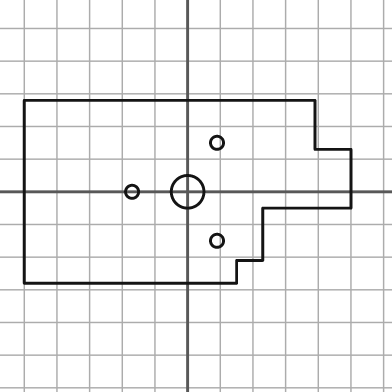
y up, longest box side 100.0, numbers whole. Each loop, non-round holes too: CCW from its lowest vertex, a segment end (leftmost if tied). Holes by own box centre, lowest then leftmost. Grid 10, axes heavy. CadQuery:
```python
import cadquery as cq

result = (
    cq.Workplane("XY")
    .moveTo(-50.0, -28.0)
    .lineTo(15.0, -28.0)
    .lineTo(15.0, -21.0)
    .lineTo(23.0, -21.0)
    .lineTo(23.0, -5.0)
    .lineTo(50.0, -5.0)
    .lineTo(50.0, 13.0)
    .lineTo(39.0, 13.0)
    .lineTo(39.0, 28.0)
    .lineTo(-50.0, 28.0)
    .close()
    .moveTo(9.0, -15.0)
    .circle(2.0)
    .moveTo(-17.0, 0.0)
    .circle(2.0)
    .moveTo(0.0, 0.0)
    .circle(5.0)
    .moveTo(9.0, 15.0)
    .circle(2.0)
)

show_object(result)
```